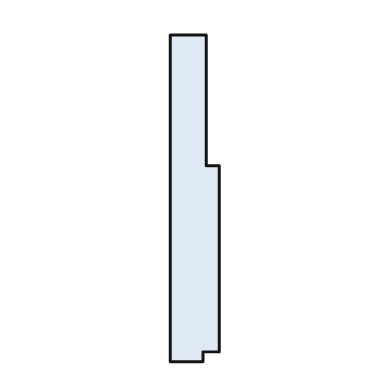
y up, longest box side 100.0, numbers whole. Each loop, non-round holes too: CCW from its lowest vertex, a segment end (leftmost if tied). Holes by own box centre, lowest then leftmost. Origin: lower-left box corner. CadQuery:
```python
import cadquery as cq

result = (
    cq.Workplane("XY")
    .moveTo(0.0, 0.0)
    .lineTo(10.0, 0.0)
    .lineTo(10.0, 3.0)
    .lineTo(15.0, 3.0)
    .lineTo(15.0, 60.0)
    .lineTo(11.0, 60.0)
    .lineTo(11.0, 100.0)
    .lineTo(0.0, 100.0)
    .close()
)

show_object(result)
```